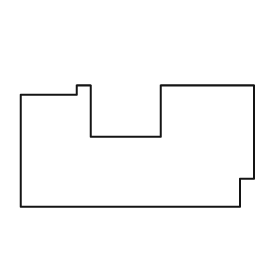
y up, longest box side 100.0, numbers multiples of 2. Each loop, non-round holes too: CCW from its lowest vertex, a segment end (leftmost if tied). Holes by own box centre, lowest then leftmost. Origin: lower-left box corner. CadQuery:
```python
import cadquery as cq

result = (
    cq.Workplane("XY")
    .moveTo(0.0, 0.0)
    .lineTo(94.0, 0.0)
    .lineTo(94.0, 12.0)
    .lineTo(100.0, 12.0)
    .lineTo(100.0, 52.0)
    .lineTo(60.0, 52.0)
    .lineTo(60.0, 30.0)
    .lineTo(30.0, 30.0)
    .lineTo(30.0, 52.0)
    .lineTo(24.0, 52.0)
    .lineTo(24.0, 48.0)
    .lineTo(0.0, 48.0)
    .close()
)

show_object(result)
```